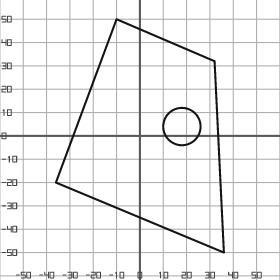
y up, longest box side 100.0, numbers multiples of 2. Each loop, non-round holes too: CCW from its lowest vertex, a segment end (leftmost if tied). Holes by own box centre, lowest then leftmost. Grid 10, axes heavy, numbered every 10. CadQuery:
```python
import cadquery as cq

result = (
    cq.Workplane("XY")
    .moveTo(36.0, -50.0)
    .lineTo(32.0, 32.0)
    .lineTo(-10.0, 50.0)
    .lineTo(-36.0, -20.0)
    .close()
    .moveTo(18.0, 4.0)
    .circle(8.0)
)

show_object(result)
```